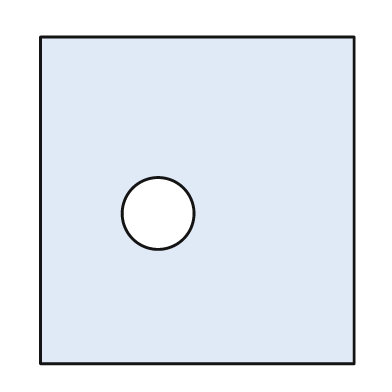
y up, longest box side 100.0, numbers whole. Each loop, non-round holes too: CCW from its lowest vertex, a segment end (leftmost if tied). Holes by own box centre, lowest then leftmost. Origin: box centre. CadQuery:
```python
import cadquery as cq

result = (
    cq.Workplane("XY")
    .moveTo(-48.0, -50.0)
    .lineTo(48.0, -50.0)
    .lineTo(48.0, 50.0)
    .lineTo(-48.0, 50.0)
    .close()
    .moveTo(-12.0, -4.0)
    .circle(11.0)
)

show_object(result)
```